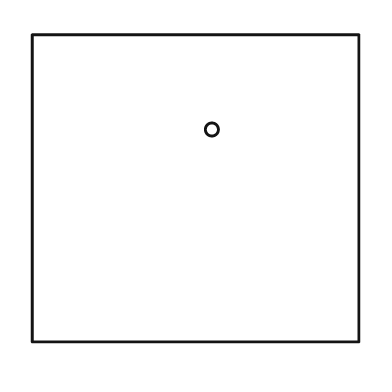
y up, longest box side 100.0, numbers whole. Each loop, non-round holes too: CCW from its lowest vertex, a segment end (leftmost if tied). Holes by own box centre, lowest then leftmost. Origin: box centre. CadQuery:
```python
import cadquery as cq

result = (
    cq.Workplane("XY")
    .moveTo(-50.0, -47.0)
    .lineTo(50.0, -47.0)
    .lineTo(50.0, 47.0)
    .lineTo(-50.0, 47.0)
    .close()
    .moveTo(5.0, 18.0)
    .circle(2.0)
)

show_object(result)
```